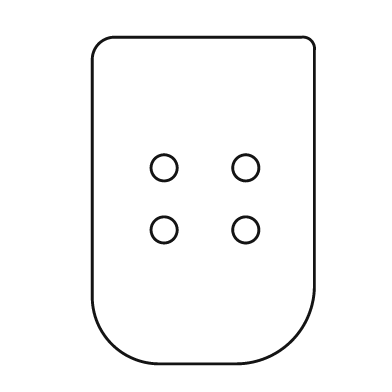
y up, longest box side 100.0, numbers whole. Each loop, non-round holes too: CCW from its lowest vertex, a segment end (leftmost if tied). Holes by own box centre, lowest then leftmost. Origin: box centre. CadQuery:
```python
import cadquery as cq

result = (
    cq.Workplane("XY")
    .moveTo(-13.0, -50.0)
    .lineTo(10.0, -50.0)
    .threePointArc((27.0, -43.0), (34.0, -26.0))
    .lineTo(34.0, 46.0)
    .threePointArc((33.0, 49.0), (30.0, 50.0))
    .lineTo(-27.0, 50.0)
    .threePointArc((-32.0, 48.0), (-34.0, 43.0))
    .lineTo(-34.0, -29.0)
    .threePointArc((-28.0, -44.0), (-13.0, -50.0))
    .close()
    .moveTo(-12.0, -9.0)
    .circle(4.0)
    .moveTo(13.0, -9.0)
    .circle(4.0)
    .moveTo(-12.0, 10.0)
    .circle(4.0)
    .moveTo(13.0, 10.0)
    .circle(4.0)
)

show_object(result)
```